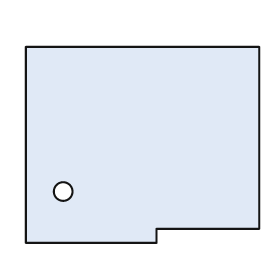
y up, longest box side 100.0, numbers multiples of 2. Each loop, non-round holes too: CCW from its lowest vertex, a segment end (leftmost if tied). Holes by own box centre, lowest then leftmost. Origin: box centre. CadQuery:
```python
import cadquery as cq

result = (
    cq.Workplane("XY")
    .moveTo(-50.0, -42.0)
    .lineTo(6.0, -42.0)
    .lineTo(6.0, -36.0)
    .lineTo(50.0, -36.0)
    .lineTo(50.0, 42.0)
    .lineTo(-50.0, 42.0)
    .close()
    .moveTo(-34.0, -20.0)
    .circle(4.0)
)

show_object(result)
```